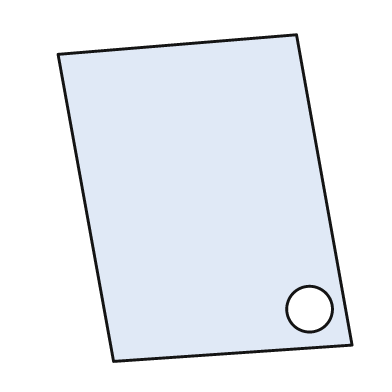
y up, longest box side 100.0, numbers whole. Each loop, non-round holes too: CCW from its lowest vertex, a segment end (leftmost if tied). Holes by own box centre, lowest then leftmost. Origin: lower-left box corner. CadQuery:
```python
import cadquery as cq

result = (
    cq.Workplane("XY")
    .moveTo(17.0, 0.0)
    .lineTo(90.0, 5.0)
    .lineTo(73.0, 100.0)
    .lineTo(0.0, 94.0)
    .close()
    .moveTo(77.0, 16.0)
    .circle(7.0)
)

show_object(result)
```